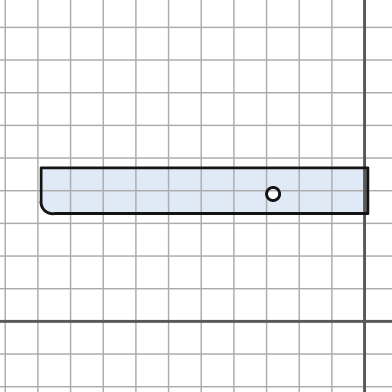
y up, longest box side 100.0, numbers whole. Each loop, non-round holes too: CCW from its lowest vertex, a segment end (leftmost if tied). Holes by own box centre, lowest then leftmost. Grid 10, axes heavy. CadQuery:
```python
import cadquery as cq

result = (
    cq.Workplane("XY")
    .moveTo(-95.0, 33.0)
    .lineTo(1.0, 33.0)
    .lineTo(1.0, 47.0)
    .lineTo(-99.0, 47.0)
    .lineTo(-99.0, 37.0)
    .threePointArc((-98.0, 34.0), (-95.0, 33.0))
    .close()
    .moveTo(-28.0, 39.0)
    .circle(2.0)
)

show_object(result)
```